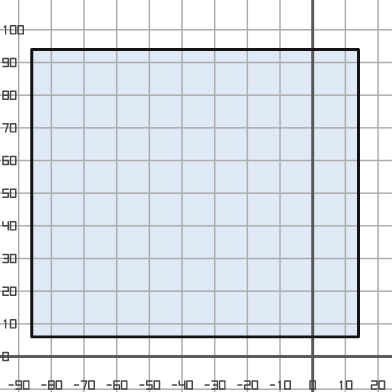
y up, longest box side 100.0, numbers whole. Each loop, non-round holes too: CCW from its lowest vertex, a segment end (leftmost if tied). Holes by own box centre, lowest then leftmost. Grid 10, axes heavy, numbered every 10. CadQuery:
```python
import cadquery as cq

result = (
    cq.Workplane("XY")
    .moveTo(-86.0, 6.0)
    .lineTo(14.0, 6.0)
    .lineTo(14.0, 94.0)
    .lineTo(-86.0, 94.0)
    .close()
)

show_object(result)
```